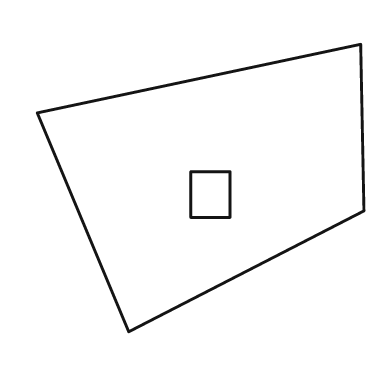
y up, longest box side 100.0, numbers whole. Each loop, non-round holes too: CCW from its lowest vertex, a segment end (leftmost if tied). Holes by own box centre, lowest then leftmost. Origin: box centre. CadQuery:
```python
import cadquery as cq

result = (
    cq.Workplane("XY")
    .moveTo(-22.0, -44.0)
    .lineTo(50.0, -7.0)
    .lineTo(49.0, 44.0)
    .lineTo(-50.0, 23.0)
    .close()
    .moveTo(-3.0, -9.0)
    .lineTo(9.0, -9.0)
    .lineTo(9.0, 5.0)
    .lineTo(-3.0, 5.0)
    .close()
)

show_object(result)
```